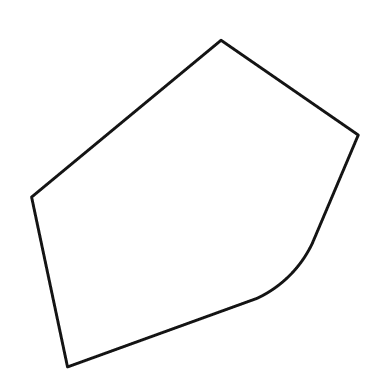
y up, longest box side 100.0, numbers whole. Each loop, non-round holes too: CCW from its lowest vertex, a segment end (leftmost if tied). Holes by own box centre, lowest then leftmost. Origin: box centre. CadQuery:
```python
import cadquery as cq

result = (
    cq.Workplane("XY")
    .moveTo(-39.0, -50.0)
    .lineTo(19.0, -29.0)
    .threePointArc((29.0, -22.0), (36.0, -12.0))
    .lineTo(50.0, 21.0)
    .lineTo(8.0, 50.0)
    .lineTo(-50.0, 2.0)
    .close()
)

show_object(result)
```